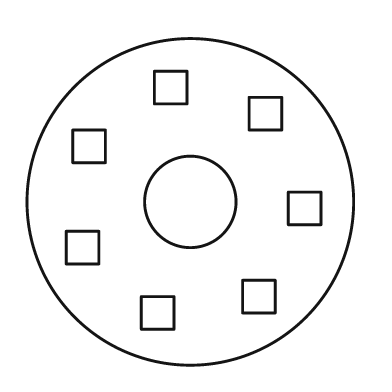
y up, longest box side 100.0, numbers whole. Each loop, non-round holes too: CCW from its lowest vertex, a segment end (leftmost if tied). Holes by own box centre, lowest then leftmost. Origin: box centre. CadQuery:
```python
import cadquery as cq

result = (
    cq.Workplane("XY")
    .moveTo(0.0, 0.0)
    .circle(50.0)
    .moveTo(-15.0, -39.0)
    .lineTo(-5.0, -39.0)
    .lineTo(-5.0, -29.0)
    .lineTo(-15.0, -29.0)
    .close()
    .moveTo(16.0, -34.0)
    .lineTo(26.0, -34.0)
    .lineTo(26.0, -24.0)
    .lineTo(16.0, -24.0)
    .close()
    .moveTo(-38.0, -19.0)
    .lineTo(-28.0, -19.0)
    .lineTo(-28.0, -9.0)
    .lineTo(-38.0, -9.0)
    .close()
    .moveTo(30.0, -7.0)
    .lineTo(40.0, -7.0)
    .lineTo(40.0, 3.0)
    .lineTo(30.0, 3.0)
    .close()
    .moveTo(0.0, 0.0)
    .circle(14.0)
    .moveTo(-36.0, 12.0)
    .lineTo(-26.0, 12.0)
    .lineTo(-26.0, 22.0)
    .lineTo(-36.0, 22.0)
    .close()
    .moveTo(18.0, 22.0)
    .lineTo(28.0, 22.0)
    .lineTo(28.0, 32.0)
    .lineTo(18.0, 32.0)
    .close()
    .moveTo(-11.0, 30.0)
    .lineTo(-1.0, 30.0)
    .lineTo(-1.0, 40.0)
    .lineTo(-11.0, 40.0)
    .close()
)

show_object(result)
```